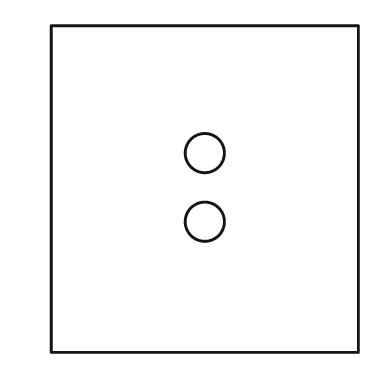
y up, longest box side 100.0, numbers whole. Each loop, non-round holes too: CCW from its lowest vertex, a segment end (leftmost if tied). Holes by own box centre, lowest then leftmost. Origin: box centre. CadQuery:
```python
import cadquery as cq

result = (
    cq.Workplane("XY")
    .moveTo(-47.0, -50.0)
    .lineTo(47.0, -50.0)
    .lineTo(47.0, 50.0)
    .lineTo(-47.0, 50.0)
    .close()
    .moveTo(0.0, -10.0)
    .circle(6.0)
    .moveTo(0.0, 11.0)
    .circle(6.0)
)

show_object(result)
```